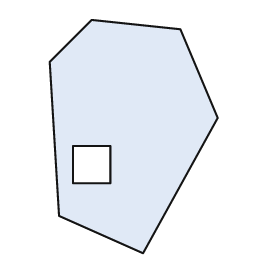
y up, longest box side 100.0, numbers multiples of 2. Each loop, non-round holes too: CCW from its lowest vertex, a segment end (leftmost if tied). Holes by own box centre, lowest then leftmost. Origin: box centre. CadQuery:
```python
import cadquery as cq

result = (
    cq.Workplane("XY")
    .moveTo(4.0, -50.0)
    .lineTo(36.0, 8.0)
    .lineTo(20.0, 46.0)
    .lineTo(-18.0, 50.0)
    .lineTo(-36.0, 32.0)
    .lineTo(-32.0, -34.0)
    .close()
    .moveTo(-26.0, -20.0)
    .lineTo(-10.0, -20.0)
    .lineTo(-10.0, -4.0)
    .lineTo(-26.0, -4.0)
    .close()
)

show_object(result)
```